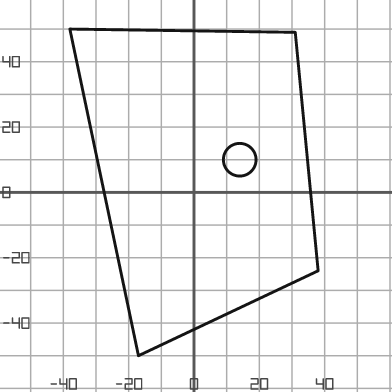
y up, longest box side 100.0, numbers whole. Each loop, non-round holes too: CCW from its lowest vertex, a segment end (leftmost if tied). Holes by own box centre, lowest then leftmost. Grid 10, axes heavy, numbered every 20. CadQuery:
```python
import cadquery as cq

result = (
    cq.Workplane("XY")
    .moveTo(-17.0, -50.0)
    .lineTo(38.0, -24.0)
    .lineTo(31.0, 49.0)
    .lineTo(-38.0, 50.0)
    .close()
    .moveTo(14.0, 10.0)
    .circle(5.0)
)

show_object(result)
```